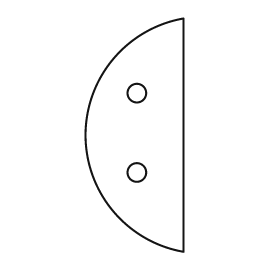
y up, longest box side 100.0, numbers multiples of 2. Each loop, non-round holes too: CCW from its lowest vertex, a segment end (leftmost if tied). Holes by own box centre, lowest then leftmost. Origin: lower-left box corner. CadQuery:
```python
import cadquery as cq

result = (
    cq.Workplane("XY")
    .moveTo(42.0, 0.0)
    .lineTo(42.0, 100.0)
    .threePointArc((0.0, 50.0), (42.0, 0.0))
    .close()
    .moveTo(22.0, 34.0)
    .circle(4.0)
    .moveTo(22.0, 68.0)
    .circle(4.0)
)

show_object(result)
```